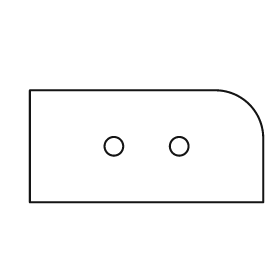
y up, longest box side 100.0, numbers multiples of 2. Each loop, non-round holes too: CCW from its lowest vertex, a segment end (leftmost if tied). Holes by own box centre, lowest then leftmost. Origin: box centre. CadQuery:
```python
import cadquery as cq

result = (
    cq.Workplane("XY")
    .moveTo(-50.0, -24.0)
    .lineTo(50.0, -24.0)
    .lineTo(50.0, 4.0)
    .threePointArc((44.0, 18.0), (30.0, 24.0))
    .lineTo(-50.0, 24.0)
    .close()
    .moveTo(-14.0, 0.0)
    .circle(4.0)
    .moveTo(14.0, 0.0)
    .circle(4.0)
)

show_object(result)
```